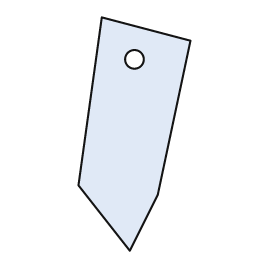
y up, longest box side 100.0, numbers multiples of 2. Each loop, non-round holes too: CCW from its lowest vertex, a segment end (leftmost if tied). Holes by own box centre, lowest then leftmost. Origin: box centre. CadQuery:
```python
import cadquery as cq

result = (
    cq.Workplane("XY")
    .moveTo(-2.0, -50.0)
    .lineTo(10.0, -26.0)
    .lineTo(24.0, 40.0)
    .lineTo(-14.0, 50.0)
    .lineTo(-24.0, -22.0)
    .close()
    .moveTo(0.0, 32.0)
    .circle(4.0)
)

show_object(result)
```